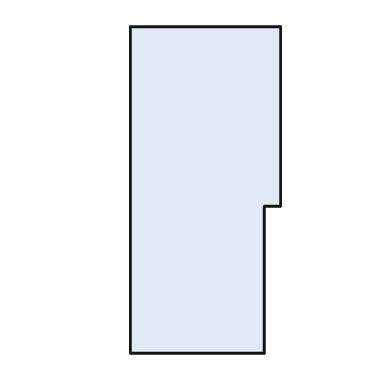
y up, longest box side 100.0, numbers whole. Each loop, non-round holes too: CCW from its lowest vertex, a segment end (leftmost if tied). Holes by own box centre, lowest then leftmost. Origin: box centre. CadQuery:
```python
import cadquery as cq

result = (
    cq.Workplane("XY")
    .moveTo(-23.0, -50.0)
    .lineTo(18.0, -50.0)
    .lineTo(18.0, -5.0)
    .lineTo(23.0, -5.0)
    .lineTo(23.0, 50.0)
    .lineTo(-23.0, 50.0)
    .close()
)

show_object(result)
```